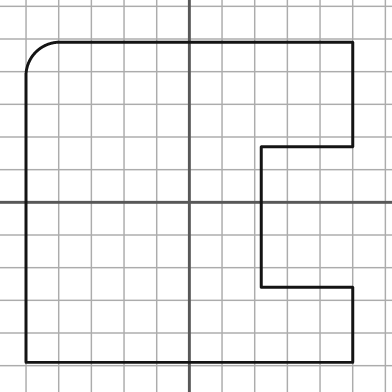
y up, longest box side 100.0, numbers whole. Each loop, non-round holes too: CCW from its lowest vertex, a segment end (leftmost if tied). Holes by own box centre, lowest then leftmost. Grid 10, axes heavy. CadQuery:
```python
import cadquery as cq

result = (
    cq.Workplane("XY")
    .moveTo(-50.0, -49.0)
    .lineTo(50.0, -49.0)
    .lineTo(50.0, -26.0)
    .lineTo(22.0, -26.0)
    .lineTo(22.0, 17.0)
    .lineTo(50.0, 17.0)
    .lineTo(50.0, 49.0)
    .lineTo(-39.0, 49.0)
    .threePointArc((-47.0, 46.0), (-50.0, 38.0))
    .close()
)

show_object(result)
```